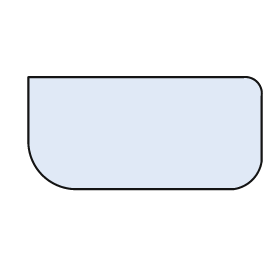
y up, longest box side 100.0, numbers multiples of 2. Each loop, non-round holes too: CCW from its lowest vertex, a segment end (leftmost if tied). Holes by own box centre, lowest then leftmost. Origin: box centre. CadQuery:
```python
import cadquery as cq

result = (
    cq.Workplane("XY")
    .moveTo(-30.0, -24.0)
    .lineTo(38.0, -24.0)
    .threePointArc((46.0, -20.0), (50.0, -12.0))
    .lineTo(50.0, 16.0)
    .threePointArc((48.0, 22.0), (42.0, 24.0))
    .lineTo(-50.0, 24.0)
    .lineTo(-50.0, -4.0)
    .threePointArc((-44.0, -18.0), (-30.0, -24.0))
    .close()
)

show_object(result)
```